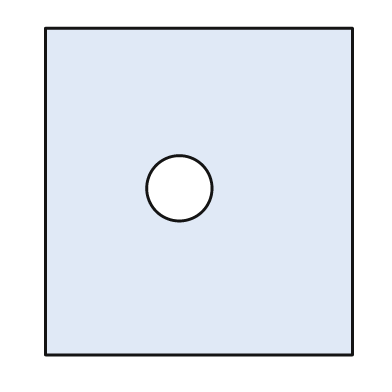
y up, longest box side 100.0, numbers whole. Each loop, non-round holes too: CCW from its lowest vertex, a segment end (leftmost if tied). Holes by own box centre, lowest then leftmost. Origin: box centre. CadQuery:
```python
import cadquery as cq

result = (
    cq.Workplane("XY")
    .moveTo(-47.0, -50.0)
    .lineTo(47.0, -50.0)
    .lineTo(47.0, 50.0)
    .lineTo(-47.0, 50.0)
    .close()
    .moveTo(-6.0, 1.0)
    .circle(10.0)
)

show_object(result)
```